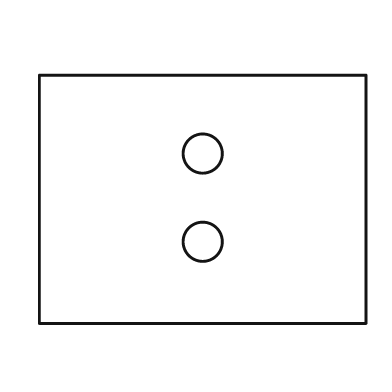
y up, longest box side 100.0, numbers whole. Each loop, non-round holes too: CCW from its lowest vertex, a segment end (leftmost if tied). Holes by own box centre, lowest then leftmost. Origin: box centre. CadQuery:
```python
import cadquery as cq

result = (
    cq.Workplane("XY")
    .moveTo(-50.0, -38.0)
    .lineTo(50.0, -38.0)
    .lineTo(50.0, 38.0)
    .lineTo(-50.0, 38.0)
    .close()
    .moveTo(0.0, -13.0)
    .circle(6.0)
    .moveTo(0.0, 14.0)
    .circle(6.0)
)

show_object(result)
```